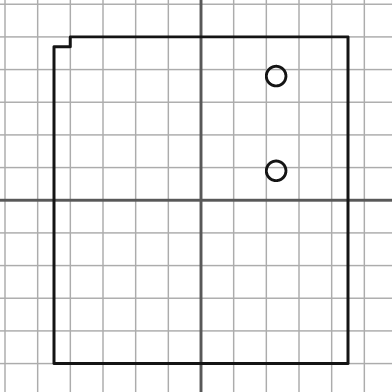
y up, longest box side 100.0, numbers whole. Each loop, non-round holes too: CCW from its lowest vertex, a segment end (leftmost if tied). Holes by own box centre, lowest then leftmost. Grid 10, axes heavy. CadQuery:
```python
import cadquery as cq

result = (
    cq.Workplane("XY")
    .moveTo(-45.0, -50.0)
    .lineTo(45.0, -50.0)
    .lineTo(45.0, 50.0)
    .lineTo(-40.0, 50.0)
    .lineTo(-40.0, 47.0)
    .lineTo(-45.0, 47.0)
    .close()
    .moveTo(23.0, 9.0)
    .circle(3.0)
    .moveTo(23.0, 38.0)
    .circle(3.0)
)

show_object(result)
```